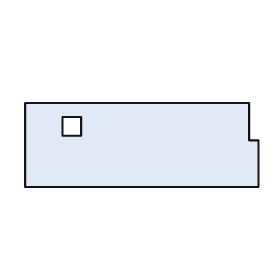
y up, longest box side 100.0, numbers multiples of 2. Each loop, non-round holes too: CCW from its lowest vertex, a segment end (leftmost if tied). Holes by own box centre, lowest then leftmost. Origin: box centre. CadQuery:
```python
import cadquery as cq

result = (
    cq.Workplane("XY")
    .moveTo(-50.0, -18.0)
    .lineTo(50.0, -18.0)
    .lineTo(50.0, 2.0)
    .lineTo(46.0, 2.0)
    .lineTo(46.0, 18.0)
    .lineTo(-50.0, 18.0)
    .close()
    .moveTo(-34.0, 4.0)
    .lineTo(-26.0, 4.0)
    .lineTo(-26.0, 12.0)
    .lineTo(-34.0, 12.0)
    .close()
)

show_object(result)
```